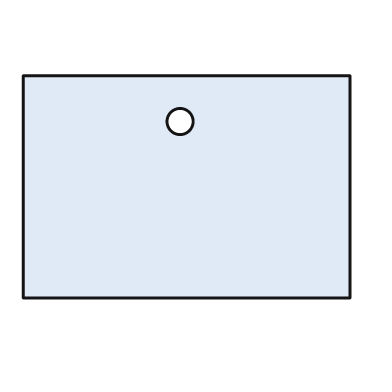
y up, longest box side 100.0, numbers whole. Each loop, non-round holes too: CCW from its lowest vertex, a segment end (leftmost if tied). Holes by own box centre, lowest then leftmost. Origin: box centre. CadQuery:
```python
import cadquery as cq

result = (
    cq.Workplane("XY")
    .moveTo(-50.0, -34.0)
    .lineTo(50.0, -34.0)
    .lineTo(50.0, 34.0)
    .lineTo(-50.0, 34.0)
    .close()
    .moveTo(-2.0, 20.0)
    .circle(4.0)
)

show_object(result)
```